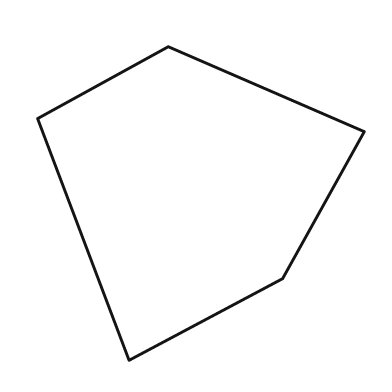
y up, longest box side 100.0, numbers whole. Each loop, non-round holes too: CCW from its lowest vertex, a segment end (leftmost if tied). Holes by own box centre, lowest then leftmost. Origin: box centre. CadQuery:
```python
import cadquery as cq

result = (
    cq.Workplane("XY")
    .moveTo(-22.0, -48.0)
    .lineTo(25.0, -23.0)
    .lineTo(50.0, 22.0)
    .lineTo(-10.0, 48.0)
    .lineTo(-50.0, 26.0)
    .close()
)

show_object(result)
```